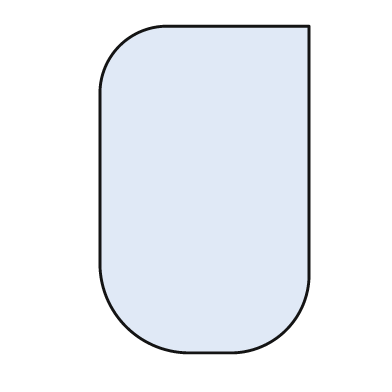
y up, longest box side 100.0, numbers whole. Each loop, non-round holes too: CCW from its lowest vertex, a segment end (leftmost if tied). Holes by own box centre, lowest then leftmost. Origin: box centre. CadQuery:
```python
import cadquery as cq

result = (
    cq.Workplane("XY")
    .moveTo(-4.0, -50.0)
    .lineTo(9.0, -50.0)
    .threePointArc((25.0, -43.0), (32.0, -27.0))
    .lineTo(32.0, 50.0)
    .lineTo(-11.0, 50.0)
    .threePointArc((-26.0, 44.0), (-32.0, 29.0))
    .lineTo(-32.0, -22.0)
    .threePointArc((-24.0, -42.0), (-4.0, -50.0))
    .close()
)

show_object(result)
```